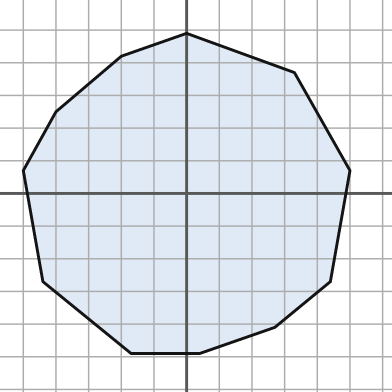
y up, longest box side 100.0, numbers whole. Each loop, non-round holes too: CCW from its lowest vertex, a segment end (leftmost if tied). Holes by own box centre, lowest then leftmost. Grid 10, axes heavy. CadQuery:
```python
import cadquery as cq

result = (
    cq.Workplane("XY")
    .moveTo(-17.0, -49.0)
    .lineTo(4.0, -49.0)
    .lineTo(27.0, -41.0)
    .lineTo(44.0, -27.0)
    .lineTo(50.0, 7.0)
    .lineTo(33.0, 37.0)
    .lineTo(0.0, 49.0)
    .lineTo(-20.0, 42.0)
    .lineTo(-40.0, 25.0)
    .lineTo(-50.0, 7.0)
    .lineTo(-44.0, -27.0)
    .close()
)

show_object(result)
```